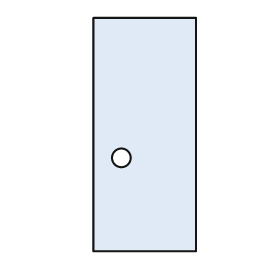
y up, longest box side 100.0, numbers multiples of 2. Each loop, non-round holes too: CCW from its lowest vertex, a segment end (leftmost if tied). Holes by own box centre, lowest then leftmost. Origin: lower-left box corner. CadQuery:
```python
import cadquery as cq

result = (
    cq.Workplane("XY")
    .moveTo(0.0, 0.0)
    .lineTo(44.0, 0.0)
    .lineTo(44.0, 100.0)
    .lineTo(0.0, 100.0)
    .close()
    .moveTo(12.0, 40.0)
    .circle(4.0)
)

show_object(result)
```